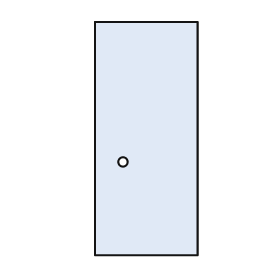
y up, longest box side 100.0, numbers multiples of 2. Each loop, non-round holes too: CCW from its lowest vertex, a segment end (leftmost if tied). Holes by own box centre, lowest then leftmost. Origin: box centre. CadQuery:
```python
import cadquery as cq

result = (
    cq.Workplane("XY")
    .moveTo(-22.0, -50.0)
    .lineTo(22.0, -50.0)
    .lineTo(22.0, 50.0)
    .lineTo(-22.0, 50.0)
    .close()
    .moveTo(-10.0, -10.0)
    .circle(2.0)
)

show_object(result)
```